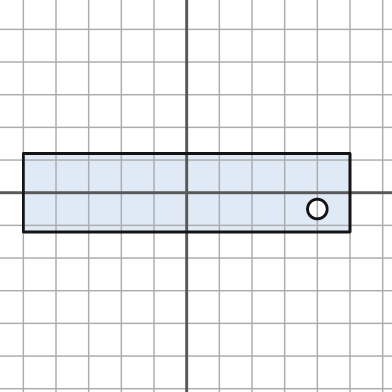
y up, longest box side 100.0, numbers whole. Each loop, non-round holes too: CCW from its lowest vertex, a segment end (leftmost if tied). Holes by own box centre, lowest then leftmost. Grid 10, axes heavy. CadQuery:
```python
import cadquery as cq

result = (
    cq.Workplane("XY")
    .moveTo(-50.0, -12.0)
    .lineTo(50.0, -12.0)
    .lineTo(50.0, 12.0)
    .lineTo(-50.0, 12.0)
    .close()
    .moveTo(40.0, -5.0)
    .circle(3.0)
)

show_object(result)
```